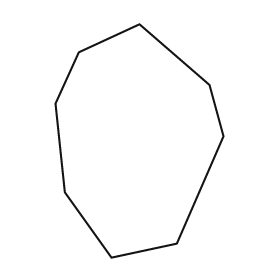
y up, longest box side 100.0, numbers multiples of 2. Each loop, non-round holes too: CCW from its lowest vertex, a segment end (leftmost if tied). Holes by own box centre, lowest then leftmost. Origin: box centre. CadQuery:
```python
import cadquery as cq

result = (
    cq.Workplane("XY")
    .moveTo(-12.0, -50.0)
    .lineTo(16.0, -44.0)
    .lineTo(36.0, 2.0)
    .lineTo(30.0, 24.0)
    .lineTo(0.0, 50.0)
    .lineTo(-26.0, 38.0)
    .lineTo(-36.0, 16.0)
    .lineTo(-32.0, -22.0)
    .close()
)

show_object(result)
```